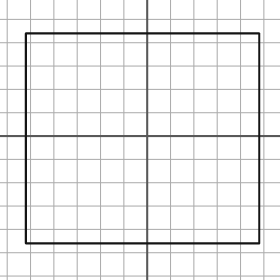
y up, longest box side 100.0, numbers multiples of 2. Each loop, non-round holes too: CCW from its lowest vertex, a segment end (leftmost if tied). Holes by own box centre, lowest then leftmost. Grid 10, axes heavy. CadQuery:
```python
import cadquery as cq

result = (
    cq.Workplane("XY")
    .moveTo(-52.0, -46.0)
    .lineTo(48.0, -46.0)
    .lineTo(48.0, 44.0)
    .lineTo(-52.0, 44.0)
    .close()
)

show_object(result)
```